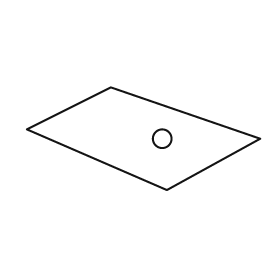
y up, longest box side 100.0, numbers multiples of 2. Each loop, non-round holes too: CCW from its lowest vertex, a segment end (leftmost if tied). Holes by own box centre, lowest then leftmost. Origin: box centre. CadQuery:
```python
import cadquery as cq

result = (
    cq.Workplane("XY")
    .moveTo(10.0, -22.0)
    .lineTo(50.0, 0.0)
    .lineTo(-14.0, 22.0)
    .lineTo(-50.0, 4.0)
    .close()
    .moveTo(8.0, 0.0)
    .circle(4.0)
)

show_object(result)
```